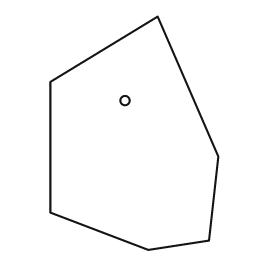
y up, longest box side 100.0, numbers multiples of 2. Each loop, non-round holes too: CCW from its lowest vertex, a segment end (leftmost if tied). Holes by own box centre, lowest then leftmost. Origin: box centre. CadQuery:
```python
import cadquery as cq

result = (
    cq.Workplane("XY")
    .moveTo(6.0, -50.0)
    .lineTo(32.0, -46.0)
    .lineTo(36.0, -10.0)
    .lineTo(10.0, 50.0)
    .lineTo(-36.0, 22.0)
    .lineTo(-36.0, -34.0)
    .close()
    .moveTo(-4.0, 14.0)
    .circle(2.0)
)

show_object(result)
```